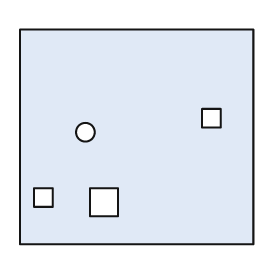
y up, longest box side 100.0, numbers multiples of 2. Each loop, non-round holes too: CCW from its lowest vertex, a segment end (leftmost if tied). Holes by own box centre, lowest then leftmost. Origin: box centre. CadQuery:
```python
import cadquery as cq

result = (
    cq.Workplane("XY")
    .moveTo(-50.0, -46.0)
    .lineTo(50.0, -46.0)
    .lineTo(50.0, 46.0)
    .lineTo(-50.0, 46.0)
    .close()
    .moveTo(-20.0, -34.0)
    .lineTo(-8.0, -34.0)
    .lineTo(-8.0, -22.0)
    .lineTo(-20.0, -22.0)
    .close()
    .moveTo(-44.0, -30.0)
    .lineTo(-36.0, -30.0)
    .lineTo(-36.0, -22.0)
    .lineTo(-44.0, -22.0)
    .close()
    .moveTo(-22.0, 2.0)
    .circle(4.0)
    .moveTo(28.0, 4.0)
    .lineTo(36.0, 4.0)
    .lineTo(36.0, 12.0)
    .lineTo(28.0, 12.0)
    .close()
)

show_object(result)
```